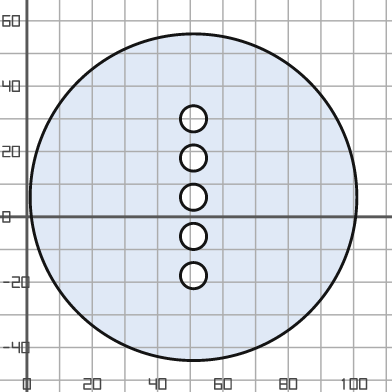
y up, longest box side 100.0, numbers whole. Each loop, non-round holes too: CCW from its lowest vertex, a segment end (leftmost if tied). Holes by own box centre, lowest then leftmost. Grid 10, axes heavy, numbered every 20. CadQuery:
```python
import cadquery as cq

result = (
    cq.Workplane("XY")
    .moveTo(51.0, 6.0)
    .circle(50.0)
    .moveTo(51.0, -18.0)
    .circle(4.0)
    .moveTo(51.0, -6.0)
    .circle(4.0)
    .moveTo(51.0, 6.0)
    .circle(4.0)
    .moveTo(51.0, 18.0)
    .circle(4.0)
    .moveTo(51.0, 30.0)
    .circle(4.0)
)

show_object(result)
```